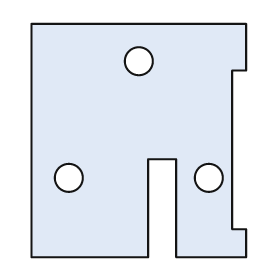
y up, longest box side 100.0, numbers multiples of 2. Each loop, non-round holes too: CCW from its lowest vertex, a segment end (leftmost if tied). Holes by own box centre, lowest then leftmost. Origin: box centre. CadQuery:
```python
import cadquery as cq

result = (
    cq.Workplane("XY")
    .moveTo(-46.0, -50.0)
    .lineTo(4.0, -50.0)
    .lineTo(4.0, -8.0)
    .lineTo(16.0, -8.0)
    .lineTo(16.0, -50.0)
    .lineTo(46.0, -50.0)
    .lineTo(46.0, -38.0)
    .lineTo(40.0, -38.0)
    .lineTo(40.0, 30.0)
    .lineTo(46.0, 30.0)
    .lineTo(46.0, 50.0)
    .lineTo(-46.0, 50.0)
    .close()
    .moveTo(-30.0, -16.0)
    .circle(6.0)
    .moveTo(30.0, -16.0)
    .circle(6.0)
    .moveTo(0.0, 34.0)
    .circle(6.0)
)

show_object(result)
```